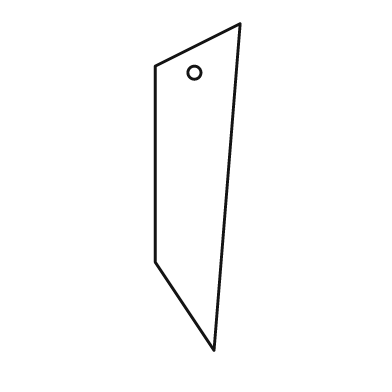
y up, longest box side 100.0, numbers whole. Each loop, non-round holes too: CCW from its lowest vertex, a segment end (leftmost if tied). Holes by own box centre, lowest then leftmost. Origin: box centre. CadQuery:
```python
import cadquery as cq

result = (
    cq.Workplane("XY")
    .moveTo(5.0, -50.0)
    .lineTo(13.0, 50.0)
    .lineTo(-13.0, 37.0)
    .lineTo(-13.0, -23.0)
    .close()
    .moveTo(-1.0, 35.0)
    .circle(2.0)
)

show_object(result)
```